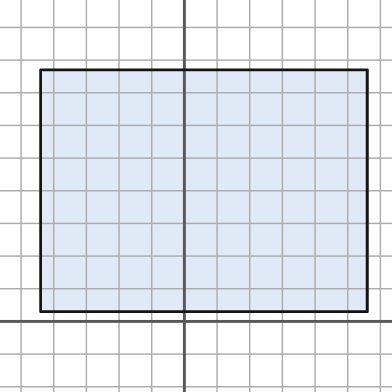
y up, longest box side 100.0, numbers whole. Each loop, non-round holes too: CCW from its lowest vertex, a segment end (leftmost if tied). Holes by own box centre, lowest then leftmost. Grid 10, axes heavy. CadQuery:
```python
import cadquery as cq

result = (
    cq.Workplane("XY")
    .moveTo(-44.0, 3.0)
    .lineTo(56.0, 3.0)
    .lineTo(56.0, 77.0)
    .lineTo(-44.0, 77.0)
    .close()
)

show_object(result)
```